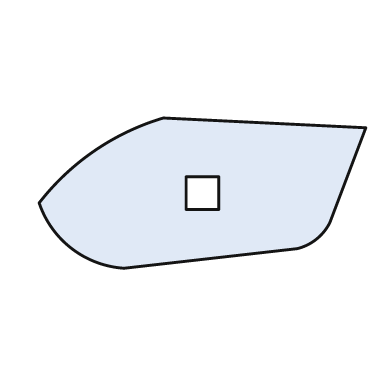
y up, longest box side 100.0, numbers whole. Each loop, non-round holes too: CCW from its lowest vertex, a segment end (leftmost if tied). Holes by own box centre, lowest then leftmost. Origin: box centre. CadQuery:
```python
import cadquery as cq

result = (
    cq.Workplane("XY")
    .moveTo(-24.0, -23.0)
    .lineTo(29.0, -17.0)
    .threePointArc((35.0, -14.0), (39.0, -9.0))
    .lineTo(50.0, 20.0)
    .lineTo(-12.0, 23.0)
    .threePointArc((-33.0, 13.0), (-50.0, -3.0))
    .threePointArc((-40.0, -17.0), (-24.0, -23.0))
    .close()
    .moveTo(-5.0, -5.0)
    .lineTo(5.0, -5.0)
    .lineTo(5.0, 5.0)
    .lineTo(-5.0, 5.0)
    .close()
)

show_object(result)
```